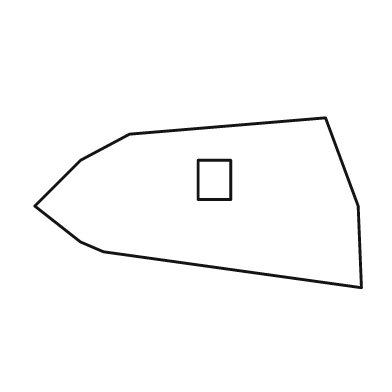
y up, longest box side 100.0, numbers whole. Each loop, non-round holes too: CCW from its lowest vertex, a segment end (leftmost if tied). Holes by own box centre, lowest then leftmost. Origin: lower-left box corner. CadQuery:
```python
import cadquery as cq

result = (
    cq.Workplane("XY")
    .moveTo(100.0, 0.0)
    .lineTo(99.0, 25.0)
    .lineTo(89.0, 52.0)
    .lineTo(29.0, 47.0)
    .lineTo(14.0, 39.0)
    .lineTo(0.0, 25.0)
    .lineTo(14.0, 14.0)
    .lineTo(21.0, 11.0)
    .close()
    .moveTo(50.0, 27.0)
    .lineTo(60.0, 27.0)
    .lineTo(60.0, 39.0)
    .lineTo(50.0, 39.0)
    .close()
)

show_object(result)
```